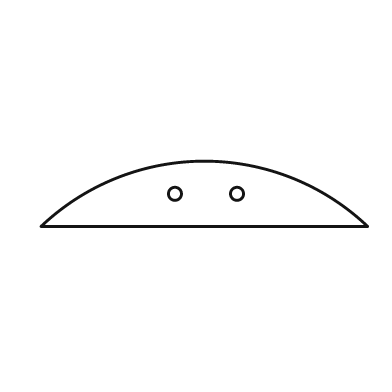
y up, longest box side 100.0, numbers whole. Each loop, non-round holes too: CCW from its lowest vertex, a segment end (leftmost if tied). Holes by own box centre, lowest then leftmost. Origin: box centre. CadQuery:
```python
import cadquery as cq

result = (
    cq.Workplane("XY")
    .moveTo(-50.0, -10.0)
    .lineTo(50.0, -10.0)
    .threePointArc((0.0, 10.0), (-50.0, -10.0))
    .close()
    .moveTo(-9.0, 0.0)
    .circle(2.0)
    .moveTo(10.0, 0.0)
    .circle(2.0)
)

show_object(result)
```